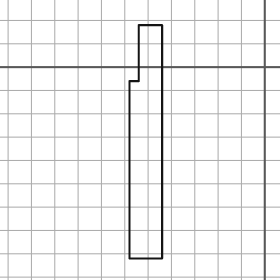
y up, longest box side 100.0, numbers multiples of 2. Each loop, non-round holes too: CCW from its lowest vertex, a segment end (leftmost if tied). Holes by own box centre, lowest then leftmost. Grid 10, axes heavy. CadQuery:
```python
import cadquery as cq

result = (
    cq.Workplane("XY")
    .moveTo(-58.0, -82.0)
    .lineTo(-44.0, -82.0)
    .lineTo(-44.0, 18.0)
    .lineTo(-54.0, 18.0)
    .lineTo(-54.0, -6.0)
    .lineTo(-58.0, -6.0)
    .close()
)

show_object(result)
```